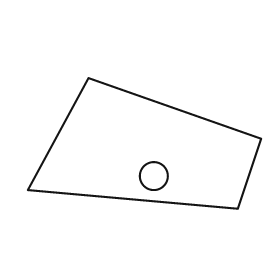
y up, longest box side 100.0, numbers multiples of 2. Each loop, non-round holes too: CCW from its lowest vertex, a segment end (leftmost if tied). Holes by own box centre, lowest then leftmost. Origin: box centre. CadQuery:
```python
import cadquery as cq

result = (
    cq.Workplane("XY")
    .moveTo(40.0, -28.0)
    .lineTo(50.0, 2.0)
    .lineTo(-24.0, 28.0)
    .lineTo(-50.0, -20.0)
    .close()
    .moveTo(4.0, -14.0)
    .circle(6.0)
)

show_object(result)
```